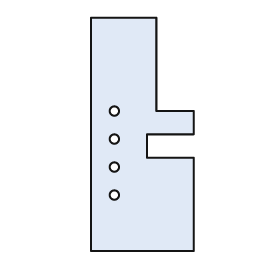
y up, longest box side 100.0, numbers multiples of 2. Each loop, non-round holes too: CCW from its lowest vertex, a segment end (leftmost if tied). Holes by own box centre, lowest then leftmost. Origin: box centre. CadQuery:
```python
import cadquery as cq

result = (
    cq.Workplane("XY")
    .moveTo(-22.0, -50.0)
    .lineTo(22.0, -50.0)
    .lineTo(22.0, -10.0)
    .lineTo(2.0, -10.0)
    .lineTo(2.0, 0.0)
    .lineTo(22.0, 0.0)
    .lineTo(22.0, 10.0)
    .lineTo(6.0, 10.0)
    .lineTo(6.0, 50.0)
    .lineTo(-22.0, 50.0)
    .close()
    .moveTo(-12.0, -26.0)
    .circle(2.0)
    .moveTo(-12.0, -14.0)
    .circle(2.0)
    .moveTo(-12.0, -2.0)
    .circle(2.0)
    .moveTo(-12.0, 10.0)
    .circle(2.0)
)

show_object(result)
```